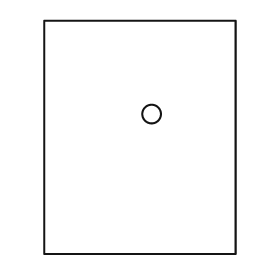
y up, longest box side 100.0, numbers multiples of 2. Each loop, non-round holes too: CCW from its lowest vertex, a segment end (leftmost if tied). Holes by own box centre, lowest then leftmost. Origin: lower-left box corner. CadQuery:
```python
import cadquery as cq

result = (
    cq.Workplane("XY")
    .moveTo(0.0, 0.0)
    .lineTo(82.0, 0.0)
    .lineTo(82.0, 100.0)
    .lineTo(0.0, 100.0)
    .close()
    .moveTo(46.0, 60.0)
    .circle(4.0)
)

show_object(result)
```